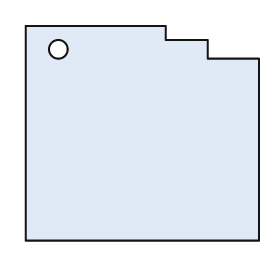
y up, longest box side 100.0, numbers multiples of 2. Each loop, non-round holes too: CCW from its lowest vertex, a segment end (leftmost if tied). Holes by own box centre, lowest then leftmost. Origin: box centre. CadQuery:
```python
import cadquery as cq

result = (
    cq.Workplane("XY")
    .moveTo(-50.0, -46.0)
    .lineTo(50.0, -46.0)
    .lineTo(50.0, 32.0)
    .lineTo(28.0, 32.0)
    .lineTo(28.0, 40.0)
    .lineTo(10.0, 40.0)
    .lineTo(10.0, 46.0)
    .lineTo(-50.0, 46.0)
    .close()
    .moveTo(-36.0, 36.0)
    .circle(4.0)
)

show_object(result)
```